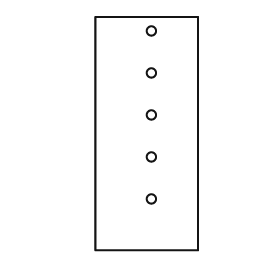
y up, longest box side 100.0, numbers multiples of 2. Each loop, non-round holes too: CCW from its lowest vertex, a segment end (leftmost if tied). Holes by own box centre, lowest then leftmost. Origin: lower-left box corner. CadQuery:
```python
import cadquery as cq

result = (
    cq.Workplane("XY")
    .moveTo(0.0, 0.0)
    .lineTo(44.0, 0.0)
    .lineTo(44.0, 100.0)
    .lineTo(0.0, 100.0)
    .close()
    .moveTo(24.0, 22.0)
    .circle(2.0)
    .moveTo(24.0, 40.0)
    .circle(2.0)
    .moveTo(24.0, 58.0)
    .circle(2.0)
    .moveTo(24.0, 76.0)
    .circle(2.0)
    .moveTo(24.0, 94.0)
    .circle(2.0)
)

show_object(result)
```